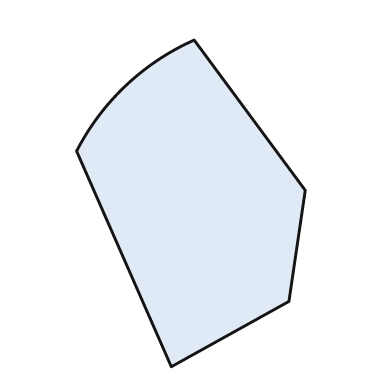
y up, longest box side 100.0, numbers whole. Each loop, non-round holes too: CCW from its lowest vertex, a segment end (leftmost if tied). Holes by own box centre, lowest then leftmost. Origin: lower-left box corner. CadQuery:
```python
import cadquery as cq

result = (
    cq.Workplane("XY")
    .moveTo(29.0, 0.0)
    .lineTo(65.0, 20.0)
    .lineTo(70.0, 54.0)
    .lineTo(36.0, 100.0)
    .threePointArc((15.0, 86.0), (0.0, 66.0))
    .close()
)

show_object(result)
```